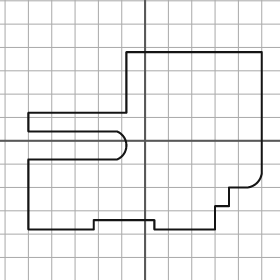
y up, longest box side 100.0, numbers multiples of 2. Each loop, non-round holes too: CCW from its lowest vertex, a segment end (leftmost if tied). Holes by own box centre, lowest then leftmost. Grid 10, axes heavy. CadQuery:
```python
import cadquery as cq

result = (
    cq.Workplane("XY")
    .moveTo(-50.0, -38.0)
    .lineTo(-22.0, -38.0)
    .lineTo(-22.0, -34.0)
    .lineTo(4.0, -34.0)
    .lineTo(4.0, -38.0)
    .lineTo(30.0, -38.0)
    .lineTo(30.0, -28.0)
    .lineTo(36.0, -28.0)
    .lineTo(36.0, -20.0)
    .lineTo(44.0, -20.0)
    .threePointArc((48.0, -18.0), (50.0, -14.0))
    .lineTo(50.0, 38.0)
    .lineTo(-8.0, 38.0)
    .lineTo(-8.0, 12.0)
    .lineTo(-50.0, 12.0)
    .lineTo(-50.0, 4.0)
    .lineTo(-12.0, 4.0)
    .threePointArc((-8.0, -2.0), (-12.0, -8.0))
    .lineTo(-50.0, -8.0)
    .close()
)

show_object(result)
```